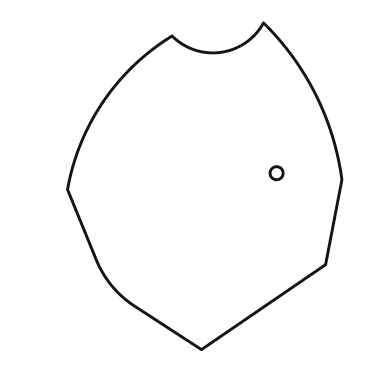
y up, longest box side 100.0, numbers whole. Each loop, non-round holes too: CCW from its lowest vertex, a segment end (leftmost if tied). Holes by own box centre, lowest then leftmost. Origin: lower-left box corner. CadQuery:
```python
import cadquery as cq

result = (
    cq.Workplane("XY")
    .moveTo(41.0, 0.0)
    .lineTo(79.0, 26.0)
    .lineTo(84.0, 52.0)
    .threePointArc((76.0, 78.0), (60.0, 100.0))
    .threePointArc((47.0, 91.0), (32.0, 96.0))
    .threePointArc((11.0, 76.0), (0.0, 49.0))
    .lineTo(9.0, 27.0)
    .threePointArc((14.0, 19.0), (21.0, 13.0))
    .close()
    .moveTo(64.0, 54.0)
    .circle(2.0)
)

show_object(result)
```